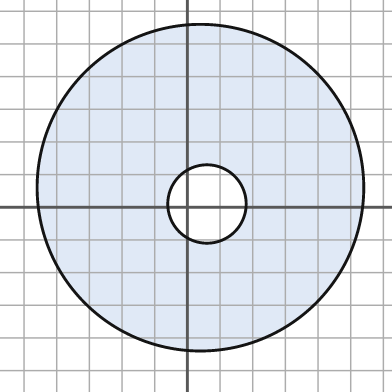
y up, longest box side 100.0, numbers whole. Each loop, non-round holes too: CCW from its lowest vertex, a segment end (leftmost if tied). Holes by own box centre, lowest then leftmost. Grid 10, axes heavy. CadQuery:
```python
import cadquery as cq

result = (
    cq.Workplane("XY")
    .moveTo(4.0, 6.0)
    .circle(50.0)
    .moveTo(6.0, 1.0)
    .circle(12.0)
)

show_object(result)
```